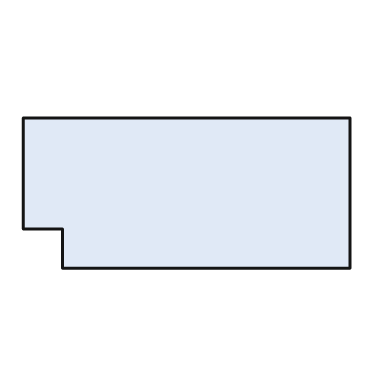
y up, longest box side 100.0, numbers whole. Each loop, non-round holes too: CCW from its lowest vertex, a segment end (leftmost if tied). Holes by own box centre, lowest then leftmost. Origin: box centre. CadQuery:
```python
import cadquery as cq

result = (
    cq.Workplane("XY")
    .moveTo(-38.0, -23.0)
    .lineTo(50.0, -23.0)
    .lineTo(50.0, 23.0)
    .lineTo(-50.0, 23.0)
    .lineTo(-50.0, -11.0)
    .lineTo(-38.0, -11.0)
    .close()
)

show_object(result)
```